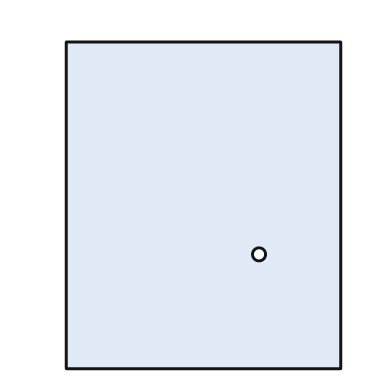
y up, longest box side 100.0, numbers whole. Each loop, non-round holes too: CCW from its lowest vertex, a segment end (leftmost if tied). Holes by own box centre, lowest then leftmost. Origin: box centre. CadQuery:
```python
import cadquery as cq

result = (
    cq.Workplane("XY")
    .moveTo(-42.0, -50.0)
    .lineTo(42.0, -50.0)
    .lineTo(42.0, 50.0)
    .lineTo(-42.0, 50.0)
    .close()
    .moveTo(17.0, -15.0)
    .circle(2.0)
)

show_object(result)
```